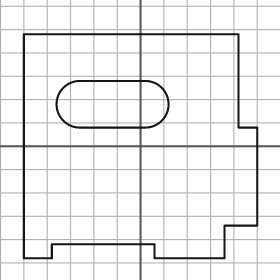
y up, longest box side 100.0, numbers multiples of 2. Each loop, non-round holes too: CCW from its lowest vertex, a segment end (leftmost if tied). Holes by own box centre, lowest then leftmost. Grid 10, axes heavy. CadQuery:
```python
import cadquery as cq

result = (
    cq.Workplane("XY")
    .moveTo(-50.0, -48.0)
    .lineTo(-38.0, -48.0)
    .lineTo(-38.0, -42.0)
    .lineTo(6.0, -42.0)
    .lineTo(6.0, -48.0)
    .lineTo(36.0, -48.0)
    .lineTo(36.0, -34.0)
    .lineTo(50.0, -34.0)
    .lineTo(50.0, 8.0)
    .lineTo(42.0, 8.0)
    .lineTo(42.0, 48.0)
    .lineTo(-50.0, 48.0)
    .close()
    .moveTo(-26.0, 8.0)
    .lineTo(2.0, 8.0)
    .threePointArc((12.0, 18.0), (2.0, 28.0))
    .lineTo(-26.0, 28.0)
    .threePointArc((-36.0, 18.0), (-26.0, 8.0))
    .close()
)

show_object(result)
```